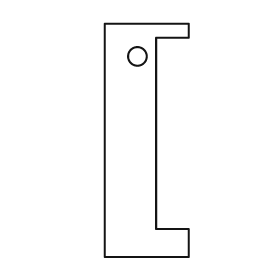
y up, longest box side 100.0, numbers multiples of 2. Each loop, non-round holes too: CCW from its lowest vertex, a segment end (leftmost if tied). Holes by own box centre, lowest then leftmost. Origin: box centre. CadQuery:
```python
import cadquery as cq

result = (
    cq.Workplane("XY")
    .moveTo(-18.0, -50.0)
    .lineTo(18.0, -50.0)
    .lineTo(18.0, -38.0)
    .lineTo(4.0, -38.0)
    .lineTo(4.0, 44.0)
    .lineTo(18.0, 44.0)
    .lineTo(18.0, 50.0)
    .lineTo(-18.0, 50.0)
    .close()
    .moveTo(-4.0, 36.0)
    .circle(4.0)
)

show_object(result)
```